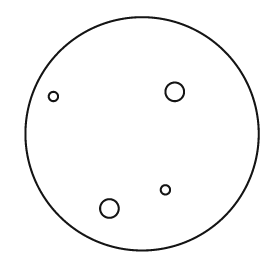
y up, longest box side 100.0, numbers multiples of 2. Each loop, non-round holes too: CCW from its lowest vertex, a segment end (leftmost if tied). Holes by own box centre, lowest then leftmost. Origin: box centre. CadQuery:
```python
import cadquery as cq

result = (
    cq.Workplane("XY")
    .moveTo(0.0, 0.0)
    .circle(50.0)
    .moveTo(-14.0, -32.0)
    .circle(4.0)
    .moveTo(10.0, -24.0)
    .circle(2.0)
    .moveTo(-38.0, 16.0)
    .circle(2.0)
    .moveTo(14.0, 18.0)
    .circle(4.0)
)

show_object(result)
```